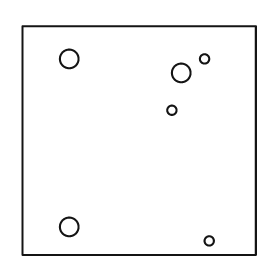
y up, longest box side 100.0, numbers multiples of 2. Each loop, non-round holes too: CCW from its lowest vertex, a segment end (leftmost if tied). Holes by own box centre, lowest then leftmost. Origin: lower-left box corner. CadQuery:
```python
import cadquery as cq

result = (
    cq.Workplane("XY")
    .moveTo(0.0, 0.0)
    .lineTo(100.0, 0.0)
    .lineTo(100.0, 98.0)
    .lineTo(0.0, 98.0)
    .close()
    .moveTo(80.0, 6.0)
    .circle(2.0)
    .moveTo(20.0, 12.0)
    .circle(4.0)
    .moveTo(64.0, 62.0)
    .circle(2.0)
    .moveTo(68.0, 78.0)
    .circle(4.0)
    .moveTo(20.0, 84.0)
    .circle(4.0)
    .moveTo(78.0, 84.0)
    .circle(2.0)
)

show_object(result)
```